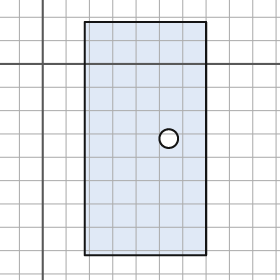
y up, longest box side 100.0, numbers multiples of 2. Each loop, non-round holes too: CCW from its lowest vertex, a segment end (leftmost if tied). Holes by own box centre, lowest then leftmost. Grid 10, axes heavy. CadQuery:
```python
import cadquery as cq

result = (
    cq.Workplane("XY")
    .moveTo(18.0, -82.0)
    .lineTo(70.0, -82.0)
    .lineTo(70.0, 18.0)
    .lineTo(18.0, 18.0)
    .close()
    .moveTo(54.0, -32.0)
    .circle(4.0)
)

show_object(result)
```